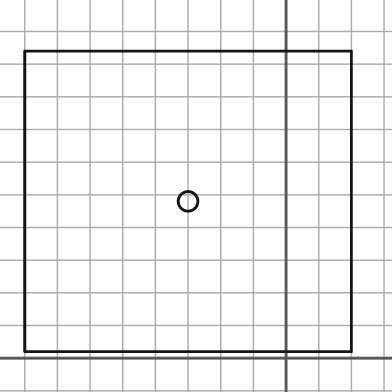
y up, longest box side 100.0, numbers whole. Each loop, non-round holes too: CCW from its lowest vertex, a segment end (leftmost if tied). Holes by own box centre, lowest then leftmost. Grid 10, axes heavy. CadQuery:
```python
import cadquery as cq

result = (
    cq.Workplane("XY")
    .moveTo(-80.0, 2.0)
    .lineTo(20.0, 2.0)
    .lineTo(20.0, 94.0)
    .lineTo(-80.0, 94.0)
    .close()
    .moveTo(-30.0, 48.0)
    .circle(3.0)
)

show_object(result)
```